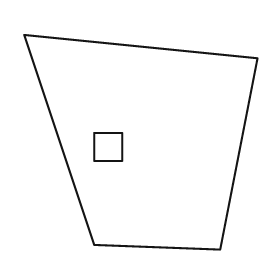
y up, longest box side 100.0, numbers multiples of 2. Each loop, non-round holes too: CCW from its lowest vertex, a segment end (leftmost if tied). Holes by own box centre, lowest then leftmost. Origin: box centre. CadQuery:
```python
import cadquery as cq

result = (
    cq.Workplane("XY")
    .moveTo(34.0, -46.0)
    .lineTo(50.0, 36.0)
    .lineTo(-50.0, 46.0)
    .lineTo(-20.0, -44.0)
    .close()
    .moveTo(-20.0, -8.0)
    .lineTo(-8.0, -8.0)
    .lineTo(-8.0, 4.0)
    .lineTo(-20.0, 4.0)
    .close()
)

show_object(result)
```